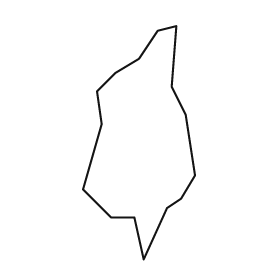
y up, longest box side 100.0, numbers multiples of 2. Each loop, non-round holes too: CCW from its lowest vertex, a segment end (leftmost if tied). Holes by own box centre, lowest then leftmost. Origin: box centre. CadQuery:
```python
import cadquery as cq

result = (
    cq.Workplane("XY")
    .moveTo(2.0, -50.0)
    .lineTo(12.0, -28.0)
    .lineTo(18.0, -24.0)
    .lineTo(24.0, -14.0)
    .lineTo(20.0, 12.0)
    .lineTo(14.0, 24.0)
    .lineTo(16.0, 50.0)
    .lineTo(8.0, 48.0)
    .lineTo(0.0, 36.0)
    .lineTo(-10.0, 30.0)
    .lineTo(-18.0, 22.0)
    .lineTo(-16.0, 8.0)
    .lineTo(-24.0, -20.0)
    .lineTo(-12.0, -32.0)
    .lineTo(-2.0, -32.0)
    .close()
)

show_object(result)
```